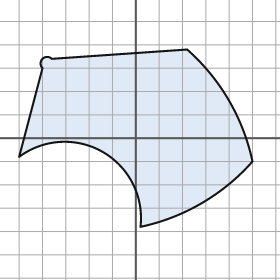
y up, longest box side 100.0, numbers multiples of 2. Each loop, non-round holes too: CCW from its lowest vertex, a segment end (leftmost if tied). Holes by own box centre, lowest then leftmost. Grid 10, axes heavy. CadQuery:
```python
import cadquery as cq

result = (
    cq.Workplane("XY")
    .moveTo(2.0, -38.0)
    .threePointArc((28.0, -28.0), (50.0, -10.0))
    .threePointArc((40.0, 16.0), (22.0, 38.0))
    .lineTo(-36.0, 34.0)
    .threePointArc((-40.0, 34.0), (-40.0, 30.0))
    .lineTo(-50.0, -8.0)
    .threePointArc((-14.0, -6.0), (2.0, -38.0))
    .close()
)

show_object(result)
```